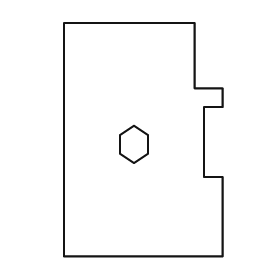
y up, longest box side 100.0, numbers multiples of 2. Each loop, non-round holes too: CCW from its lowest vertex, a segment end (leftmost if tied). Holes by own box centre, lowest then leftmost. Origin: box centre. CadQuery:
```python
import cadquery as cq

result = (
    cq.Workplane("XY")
    .moveTo(-34.0, -50.0)
    .lineTo(34.0, -50.0)
    .lineTo(34.0, -16.0)
    .lineTo(26.0, -16.0)
    .lineTo(26.0, 14.0)
    .lineTo(34.0, 14.0)
    .lineTo(34.0, 22.0)
    .lineTo(22.0, 22.0)
    .lineTo(22.0, 50.0)
    .lineTo(-34.0, 50.0)
    .close()
    .moveTo(-4.0, -10.0)
    .lineTo(2.0, -6.0)
    .lineTo(2.0, 2.0)
    .lineTo(-4.0, 6.0)
    .lineTo(-10.0, 2.0)
    .lineTo(-10.0, -6.0)
    .close()
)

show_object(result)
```